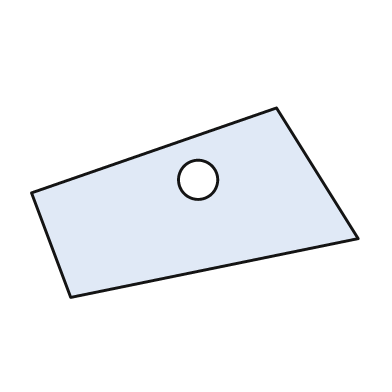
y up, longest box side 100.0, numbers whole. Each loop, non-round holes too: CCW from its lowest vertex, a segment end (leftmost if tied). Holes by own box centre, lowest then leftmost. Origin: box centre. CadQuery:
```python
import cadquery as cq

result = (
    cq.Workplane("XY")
    .moveTo(-38.0, -29.0)
    .lineTo(50.0, -11.0)
    .lineTo(25.0, 29.0)
    .lineTo(-50.0, 3.0)
    .close()
    .moveTo(1.0, 7.0)
    .circle(6.0)
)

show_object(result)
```